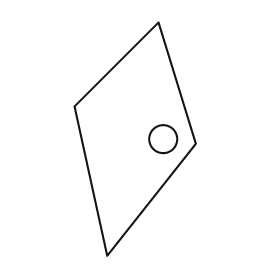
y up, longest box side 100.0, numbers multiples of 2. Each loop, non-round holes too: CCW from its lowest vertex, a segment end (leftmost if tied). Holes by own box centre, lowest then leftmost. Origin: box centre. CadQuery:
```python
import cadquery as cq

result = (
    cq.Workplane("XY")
    .moveTo(-12.0, -50.0)
    .lineTo(26.0, -2.0)
    .lineTo(10.0, 50.0)
    .lineTo(-26.0, 14.0)
    .close()
    .moveTo(12.0, 0.0)
    .circle(6.0)
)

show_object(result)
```